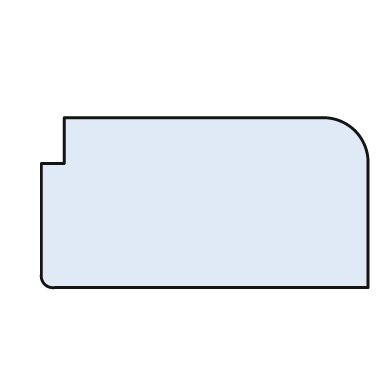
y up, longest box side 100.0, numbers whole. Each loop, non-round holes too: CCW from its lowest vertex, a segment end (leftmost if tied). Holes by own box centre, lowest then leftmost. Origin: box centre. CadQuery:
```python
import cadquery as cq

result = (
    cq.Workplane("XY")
    .moveTo(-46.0, -26.0)
    .lineTo(50.0, -26.0)
    .lineTo(50.0, 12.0)
    .threePointArc((46.0, 22.0), (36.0, 26.0))
    .lineTo(-43.0, 26.0)
    .lineTo(-43.0, 12.0)
    .lineTo(-50.0, 12.0)
    .lineTo(-50.0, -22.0)
    .threePointArc((-49.0, -25.0), (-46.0, -26.0))
    .close()
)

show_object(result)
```